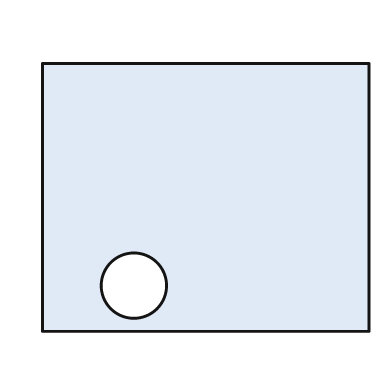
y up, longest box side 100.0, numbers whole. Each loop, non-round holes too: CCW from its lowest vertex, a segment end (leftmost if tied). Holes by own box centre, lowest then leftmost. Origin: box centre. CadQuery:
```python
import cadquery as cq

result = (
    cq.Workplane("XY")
    .moveTo(-50.0, -41.0)
    .lineTo(50.0, -41.0)
    .lineTo(50.0, 41.0)
    .lineTo(-50.0, 41.0)
    .close()
    .moveTo(-22.0, -27.0)
    .circle(10.0)
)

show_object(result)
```